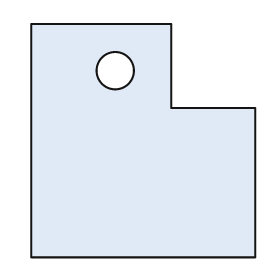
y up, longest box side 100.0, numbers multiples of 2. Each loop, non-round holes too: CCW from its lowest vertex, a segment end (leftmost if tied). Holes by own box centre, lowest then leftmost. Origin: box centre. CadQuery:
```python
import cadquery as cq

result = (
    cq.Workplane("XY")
    .moveTo(-48.0, -50.0)
    .lineTo(48.0, -50.0)
    .lineTo(48.0, 14.0)
    .lineTo(12.0, 14.0)
    .lineTo(12.0, 50.0)
    .lineTo(-48.0, 50.0)
    .close()
    .moveTo(-12.0, 30.0)
    .circle(8.0)
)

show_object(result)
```